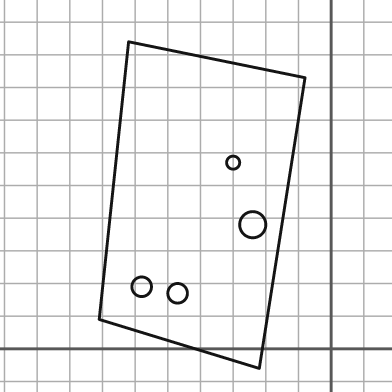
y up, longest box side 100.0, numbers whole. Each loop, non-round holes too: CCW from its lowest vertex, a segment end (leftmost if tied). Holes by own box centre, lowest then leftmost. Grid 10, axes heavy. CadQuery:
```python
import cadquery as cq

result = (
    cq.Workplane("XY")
    .moveTo(-22.0, -6.0)
    .lineTo(-8.0, 83.0)
    .lineTo(-62.0, 94.0)
    .lineTo(-71.0, 9.0)
    .close()
    .moveTo(-47.0, 17.0)
    .circle(3.0)
    .moveTo(-58.0, 19.0)
    .circle(3.0)
    .moveTo(-24.0, 38.0)
    .circle(4.0)
    .moveTo(-30.0, 57.0)
    .circle(2.0)
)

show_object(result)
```